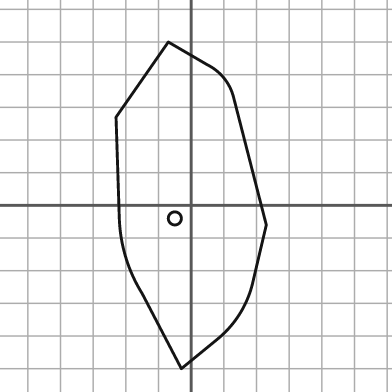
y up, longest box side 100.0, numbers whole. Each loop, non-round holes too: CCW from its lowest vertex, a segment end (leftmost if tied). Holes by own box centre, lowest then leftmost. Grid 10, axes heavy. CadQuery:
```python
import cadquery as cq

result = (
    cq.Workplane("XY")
    .moveTo(-3.0, -50.0)
    .lineTo(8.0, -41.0)
    .threePointArc((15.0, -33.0), (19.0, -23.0))
    .lineTo(23.0, -6.0)
    .lineTo(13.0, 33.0)
    .threePointArc((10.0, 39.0), (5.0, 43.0))
    .lineTo(-7.0, 50.0)
    .lineTo(-23.0, 27.0)
    .lineTo(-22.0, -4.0)
    .threePointArc((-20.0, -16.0), (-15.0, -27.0))
    .close()
    .moveTo(-5.0, -4.0)
    .circle(2.0)
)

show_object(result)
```